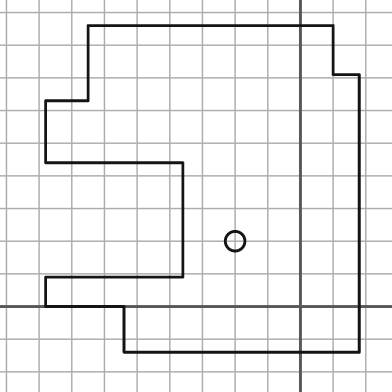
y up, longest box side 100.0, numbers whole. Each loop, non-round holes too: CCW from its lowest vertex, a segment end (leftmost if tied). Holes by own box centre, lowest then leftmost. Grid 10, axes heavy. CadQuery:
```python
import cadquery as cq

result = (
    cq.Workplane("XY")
    .moveTo(-54.0, -14.0)
    .lineTo(18.0, -14.0)
    .lineTo(18.0, 71.0)
    .lineTo(10.0, 71.0)
    .lineTo(10.0, 86.0)
    .lineTo(-65.0, 86.0)
    .lineTo(-65.0, 63.0)
    .lineTo(-78.0, 63.0)
    .lineTo(-78.0, 44.0)
    .lineTo(-36.0, 44.0)
    .lineTo(-36.0, 9.0)
    .lineTo(-78.0, 9.0)
    .lineTo(-78.0, 0.0)
    .lineTo(-54.0, 0.0)
    .close()
    .moveTo(-20.0, 20.0)
    .circle(3.0)
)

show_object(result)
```